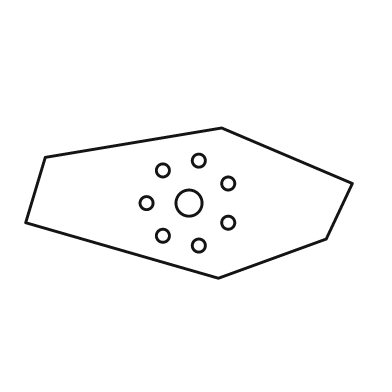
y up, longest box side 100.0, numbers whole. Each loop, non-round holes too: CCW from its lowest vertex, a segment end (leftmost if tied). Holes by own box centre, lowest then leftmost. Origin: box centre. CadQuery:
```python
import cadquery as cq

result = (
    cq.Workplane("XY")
    .moveTo(9.0, -23.0)
    .lineTo(42.0, -11.0)
    .lineTo(50.0, 6.0)
    .lineTo(10.0, 23.0)
    .lineTo(-44.0, 14.0)
    .lineTo(-50.0, -6.0)
    .close()
    .moveTo(3.0, -13.0)
    .circle(2.0)
    .moveTo(-8.0, -10.0)
    .circle(2.0)
    .moveTo(12.0, -6.0)
    .circle(2.0)
    .moveTo(-13.0, 0.0)
    .circle(2.0)
    .moveTo(0.0, 0.0)
    .circle(4.0)
    .moveTo(12.0, 6.0)
    .circle(2.0)
    .moveTo(-8.0, 10.0)
    .circle(2.0)
    .moveTo(3.0, 13.0)
    .circle(2.0)
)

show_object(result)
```